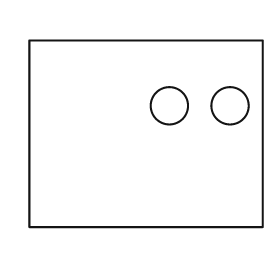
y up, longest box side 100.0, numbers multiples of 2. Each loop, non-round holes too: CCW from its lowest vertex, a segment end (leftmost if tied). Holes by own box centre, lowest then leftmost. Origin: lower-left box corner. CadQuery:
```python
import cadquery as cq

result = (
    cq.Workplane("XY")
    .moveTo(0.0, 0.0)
    .lineTo(100.0, 0.0)
    .lineTo(100.0, 80.0)
    .lineTo(0.0, 80.0)
    .close()
    .moveTo(60.0, 52.0)
    .circle(8.0)
    .moveTo(86.0, 52.0)
    .circle(8.0)
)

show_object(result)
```